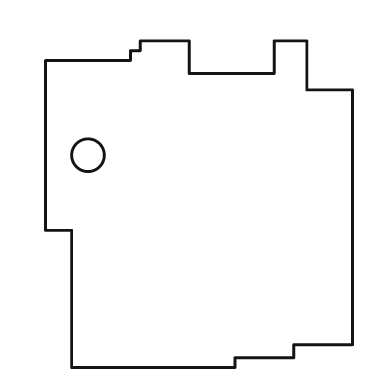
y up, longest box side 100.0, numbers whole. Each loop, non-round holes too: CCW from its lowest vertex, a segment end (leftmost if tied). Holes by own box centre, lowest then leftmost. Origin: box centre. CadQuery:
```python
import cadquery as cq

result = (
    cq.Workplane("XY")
    .moveTo(-39.0, -50.0)
    .lineTo(11.0, -50.0)
    .lineTo(11.0, -47.0)
    .lineTo(29.0, -47.0)
    .lineTo(29.0, -43.0)
    .lineTo(47.0, -43.0)
    .lineTo(47.0, 35.0)
    .lineTo(33.0, 35.0)
    .lineTo(33.0, 50.0)
    .lineTo(23.0, 50.0)
    .lineTo(23.0, 40.0)
    .lineTo(-3.0, 40.0)
    .lineTo(-3.0, 50.0)
    .lineTo(-18.0, 50.0)
    .lineTo(-18.0, 47.0)
    .lineTo(-21.0, 47.0)
    .lineTo(-21.0, 44.0)
    .lineTo(-47.0, 44.0)
    .lineTo(-47.0, -8.0)
    .lineTo(-39.0, -8.0)
    .close()
    .moveTo(-34.0, 15.0)
    .circle(5.0)
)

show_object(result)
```